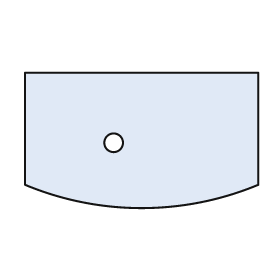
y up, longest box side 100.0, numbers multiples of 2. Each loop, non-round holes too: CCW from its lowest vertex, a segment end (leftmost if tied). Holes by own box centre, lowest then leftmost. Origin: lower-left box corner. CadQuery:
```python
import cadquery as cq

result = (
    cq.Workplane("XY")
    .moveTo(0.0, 10.0)
    .threePointArc((50.0, 0.0), (100.0, 10.0))
    .lineTo(100.0, 58.0)
    .lineTo(0.0, 58.0)
    .close()
    .moveTo(38.0, 28.0)
    .circle(4.0)
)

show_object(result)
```